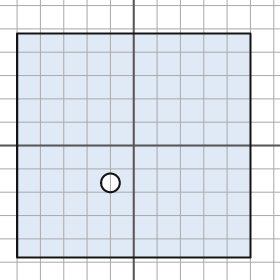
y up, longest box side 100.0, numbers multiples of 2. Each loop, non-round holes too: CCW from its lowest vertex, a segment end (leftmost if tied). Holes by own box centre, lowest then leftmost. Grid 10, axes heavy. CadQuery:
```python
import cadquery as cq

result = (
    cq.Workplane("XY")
    .moveTo(-50.0, -48.0)
    .lineTo(50.0, -48.0)
    .lineTo(50.0, 48.0)
    .lineTo(-50.0, 48.0)
    .close()
    .moveTo(-10.0, -16.0)
    .circle(4.0)
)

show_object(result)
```